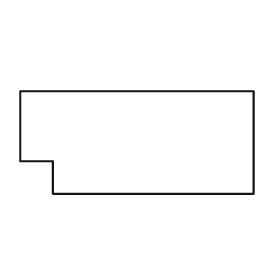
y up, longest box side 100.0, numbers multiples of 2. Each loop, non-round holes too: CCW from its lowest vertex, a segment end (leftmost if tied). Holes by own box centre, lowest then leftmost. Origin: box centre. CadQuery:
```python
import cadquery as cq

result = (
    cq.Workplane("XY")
    .moveTo(-36.0, -22.0)
    .lineTo(50.0, -22.0)
    .lineTo(50.0, 22.0)
    .lineTo(-50.0, 22.0)
    .lineTo(-50.0, -8.0)
    .lineTo(-36.0, -8.0)
    .close()
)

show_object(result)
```